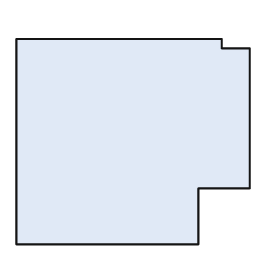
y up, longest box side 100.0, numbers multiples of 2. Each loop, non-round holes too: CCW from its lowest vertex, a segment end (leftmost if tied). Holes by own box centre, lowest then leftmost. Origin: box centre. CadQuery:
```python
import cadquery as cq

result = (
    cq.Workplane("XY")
    .moveTo(-50.0, -44.0)
    .lineTo(28.0, -44.0)
    .lineTo(28.0, -20.0)
    .lineTo(50.0, -20.0)
    .lineTo(50.0, 40.0)
    .lineTo(38.0, 40.0)
    .lineTo(38.0, 44.0)
    .lineTo(-50.0, 44.0)
    .close()
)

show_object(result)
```